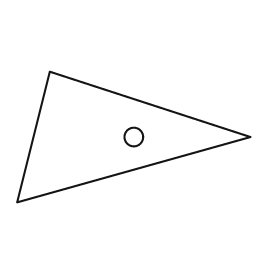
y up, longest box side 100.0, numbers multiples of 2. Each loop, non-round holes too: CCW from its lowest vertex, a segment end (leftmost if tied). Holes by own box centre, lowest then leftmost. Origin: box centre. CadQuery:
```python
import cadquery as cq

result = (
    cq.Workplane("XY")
    .moveTo(-50.0, -28.0)
    .lineTo(50.0, 0.0)
    .lineTo(-36.0, 28.0)
    .close()
    .moveTo(0.0, 0.0)
    .circle(4.0)
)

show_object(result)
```